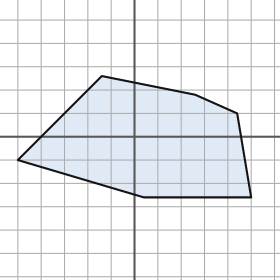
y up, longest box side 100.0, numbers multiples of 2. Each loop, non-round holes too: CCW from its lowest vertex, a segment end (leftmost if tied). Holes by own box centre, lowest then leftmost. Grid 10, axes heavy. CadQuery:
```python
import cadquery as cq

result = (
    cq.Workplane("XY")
    .moveTo(4.0, -26.0)
    .lineTo(50.0, -26.0)
    .lineTo(44.0, 10.0)
    .lineTo(26.0, 18.0)
    .lineTo(-14.0, 26.0)
    .lineTo(-50.0, -10.0)
    .close()
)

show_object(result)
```